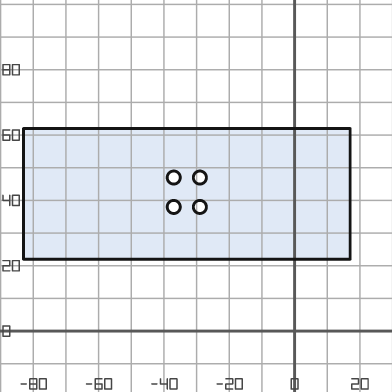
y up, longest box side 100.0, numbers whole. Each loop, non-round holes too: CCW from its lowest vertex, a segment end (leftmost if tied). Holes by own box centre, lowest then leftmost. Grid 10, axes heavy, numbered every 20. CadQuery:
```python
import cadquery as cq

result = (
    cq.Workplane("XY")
    .moveTo(-83.0, 22.0)
    .lineTo(17.0, 22.0)
    .lineTo(17.0, 62.0)
    .lineTo(-83.0, 62.0)
    .close()
    .moveTo(-37.0, 38.0)
    .circle(2.0)
    .moveTo(-29.0, 38.0)
    .circle(2.0)
    .moveTo(-37.0, 47.0)
    .circle(2.0)
    .moveTo(-29.0, 47.0)
    .circle(2.0)
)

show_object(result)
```